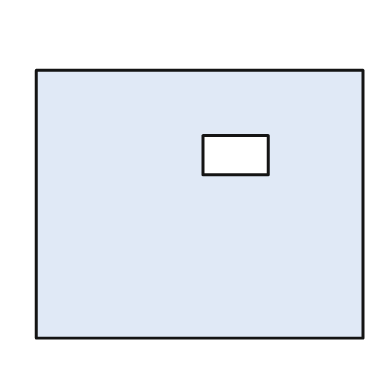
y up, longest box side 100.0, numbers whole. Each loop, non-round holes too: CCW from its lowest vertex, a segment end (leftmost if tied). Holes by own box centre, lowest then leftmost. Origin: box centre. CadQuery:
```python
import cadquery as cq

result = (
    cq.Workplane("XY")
    .moveTo(-50.0, -41.0)
    .lineTo(50.0, -41.0)
    .lineTo(50.0, 41.0)
    .lineTo(-50.0, 41.0)
    .close()
    .moveTo(1.0, 9.0)
    .lineTo(21.0, 9.0)
    .lineTo(21.0, 21.0)
    .lineTo(1.0, 21.0)
    .close()
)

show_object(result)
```